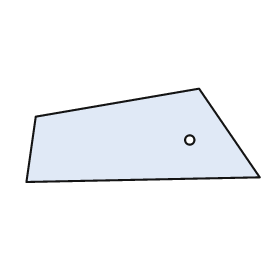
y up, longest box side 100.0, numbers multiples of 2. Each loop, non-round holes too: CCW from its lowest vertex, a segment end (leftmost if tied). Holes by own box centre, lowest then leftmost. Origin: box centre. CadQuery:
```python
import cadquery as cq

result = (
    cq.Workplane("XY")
    .moveTo(-50.0, -20.0)
    .lineTo(50.0, -18.0)
    .lineTo(24.0, 20.0)
    .lineTo(-46.0, 8.0)
    .close()
    .moveTo(20.0, -2.0)
    .circle(2.0)
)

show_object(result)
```